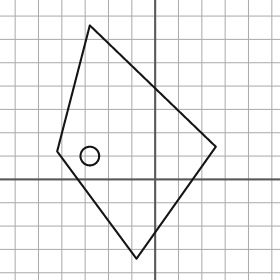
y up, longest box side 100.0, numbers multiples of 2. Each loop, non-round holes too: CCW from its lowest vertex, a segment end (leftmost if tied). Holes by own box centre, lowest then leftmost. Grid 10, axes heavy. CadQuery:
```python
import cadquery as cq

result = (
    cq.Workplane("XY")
    .moveTo(-8.0, -34.0)
    .lineTo(26.0, 14.0)
    .lineTo(-28.0, 66.0)
    .lineTo(-42.0, 12.0)
    .close()
    .moveTo(-28.0, 10.0)
    .circle(4.0)
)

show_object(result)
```